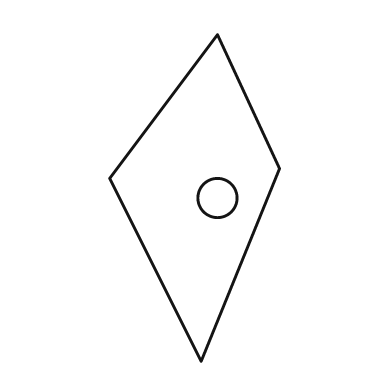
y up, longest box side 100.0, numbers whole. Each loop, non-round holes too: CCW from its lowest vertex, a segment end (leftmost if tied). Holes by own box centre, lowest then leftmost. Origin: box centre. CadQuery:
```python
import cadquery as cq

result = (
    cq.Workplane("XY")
    .moveTo(2.0, -50.0)
    .lineTo(26.0, 9.0)
    .lineTo(7.0, 50.0)
    .lineTo(-26.0, 6.0)
    .close()
    .moveTo(7.0, 0.0)
    .circle(6.0)
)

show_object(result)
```